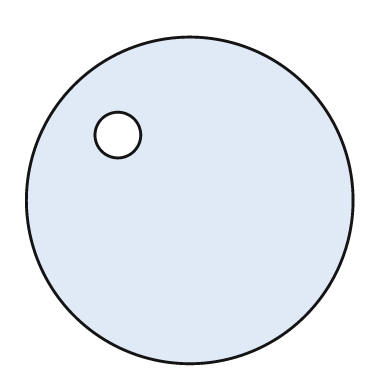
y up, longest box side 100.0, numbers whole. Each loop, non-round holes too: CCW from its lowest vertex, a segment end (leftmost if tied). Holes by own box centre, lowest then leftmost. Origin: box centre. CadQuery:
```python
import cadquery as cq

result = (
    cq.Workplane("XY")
    .moveTo(0.0, 0.0)
    .circle(50.0)
    .moveTo(-22.0, 20.0)
    .circle(7.0)
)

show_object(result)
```